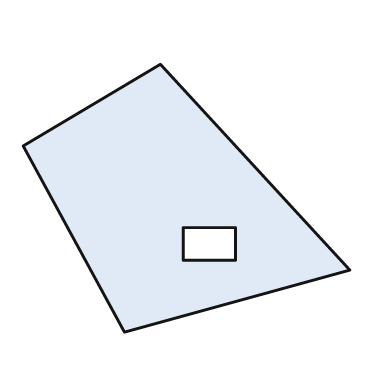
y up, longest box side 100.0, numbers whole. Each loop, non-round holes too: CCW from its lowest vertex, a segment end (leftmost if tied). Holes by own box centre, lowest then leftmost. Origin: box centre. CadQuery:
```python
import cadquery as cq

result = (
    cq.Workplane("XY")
    .moveTo(-19.0, -41.0)
    .lineTo(50.0, -22.0)
    .lineTo(-8.0, 41.0)
    .lineTo(-50.0, 16.0)
    .close()
    .moveTo(-1.0, -19.0)
    .lineTo(15.0, -19.0)
    .lineTo(15.0, -9.0)
    .lineTo(-1.0, -9.0)
    .close()
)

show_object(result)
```